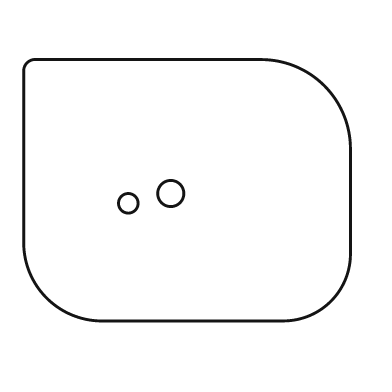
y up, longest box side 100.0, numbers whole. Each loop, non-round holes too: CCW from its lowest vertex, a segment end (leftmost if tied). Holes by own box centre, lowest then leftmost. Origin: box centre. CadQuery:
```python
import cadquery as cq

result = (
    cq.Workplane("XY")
    .moveTo(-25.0, -40.0)
    .lineTo(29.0, -40.0)
    .threePointArc((44.0, -34.0), (50.0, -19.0))
    .lineTo(50.0, 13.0)
    .threePointArc((42.0, 32.0), (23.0, 40.0))
    .lineTo(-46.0, 40.0)
    .threePointArc((-49.0, 39.0), (-50.0, 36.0))
    .lineTo(-50.0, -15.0)
    .threePointArc((-43.0, -33.0), (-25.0, -40.0))
    .close()
    .moveTo(-18.0, -4.0)
    .circle(3.0)
    .moveTo(-5.0, -1.0)
    .circle(4.0)
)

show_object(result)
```